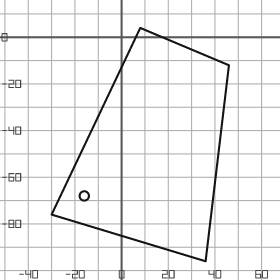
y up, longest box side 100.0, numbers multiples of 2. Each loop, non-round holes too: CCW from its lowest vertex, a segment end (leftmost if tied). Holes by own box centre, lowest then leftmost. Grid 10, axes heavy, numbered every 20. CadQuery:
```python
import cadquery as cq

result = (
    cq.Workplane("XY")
    .moveTo(36.0, -96.0)
    .lineTo(46.0, -12.0)
    .lineTo(8.0, 4.0)
    .lineTo(-30.0, -76.0)
    .close()
    .moveTo(-16.0, -68.0)
    .circle(2.0)
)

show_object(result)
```